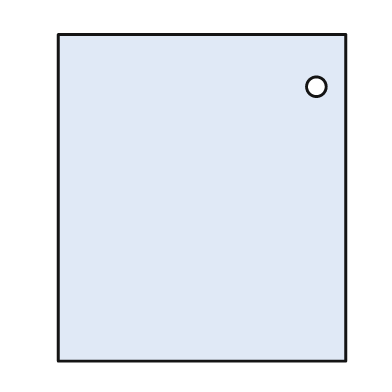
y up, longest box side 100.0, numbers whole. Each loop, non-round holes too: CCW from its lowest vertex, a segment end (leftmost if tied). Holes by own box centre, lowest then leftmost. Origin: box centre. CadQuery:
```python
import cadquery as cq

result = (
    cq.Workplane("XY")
    .moveTo(-44.0, -50.0)
    .lineTo(44.0, -50.0)
    .lineTo(44.0, 50.0)
    .lineTo(-44.0, 50.0)
    .close()
    .moveTo(35.0, 34.0)
    .circle(3.0)
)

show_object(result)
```